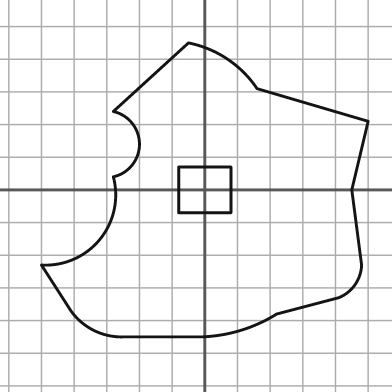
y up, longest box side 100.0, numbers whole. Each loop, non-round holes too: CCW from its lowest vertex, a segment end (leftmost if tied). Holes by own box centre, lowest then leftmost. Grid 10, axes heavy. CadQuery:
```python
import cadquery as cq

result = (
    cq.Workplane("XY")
    .moveTo(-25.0, -45.0)
    .lineTo(-1.0, -45.0)
    .threePointArc((11.0, -43.0), (22.0, -38.0))
    .lineTo(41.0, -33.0)
    .threePointArc((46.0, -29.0), (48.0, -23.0))
    .lineTo(45.0, 0.0)
    .lineTo(50.0, 21.0)
    .lineTo(16.0, 31.0)
    .threePointArc((7.0, 40.0), (-5.0, 45.0))
    .lineTo(-28.0, 24.0)
    .threePointArc((-20.0, 14.0), (-28.0, 4.0))
    .threePointArc((-32.0, -15.0), (-50.0, -23.0))
    .lineTo(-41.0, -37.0)
    .threePointArc((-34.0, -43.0), (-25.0, -45.0))
    .close()
    .moveTo(-8.0, -7.0)
    .lineTo(8.0, -7.0)
    .lineTo(8.0, 7.0)
    .lineTo(-8.0, 7.0)
    .close()
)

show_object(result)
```